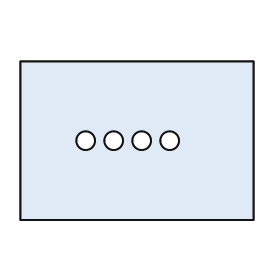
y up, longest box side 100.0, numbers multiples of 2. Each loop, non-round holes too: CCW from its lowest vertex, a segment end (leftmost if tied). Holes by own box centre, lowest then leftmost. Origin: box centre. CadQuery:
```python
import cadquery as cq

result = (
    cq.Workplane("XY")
    .moveTo(-50.0, -34.0)
    .lineTo(50.0, -34.0)
    .lineTo(50.0, 34.0)
    .lineTo(-50.0, 34.0)
    .close()
    .moveTo(-22.0, 0.0)
    .circle(4.0)
    .moveTo(-10.0, 0.0)
    .circle(4.0)
    .moveTo(2.0, 0.0)
    .circle(4.0)
    .moveTo(14.0, 0.0)
    .circle(4.0)
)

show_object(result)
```